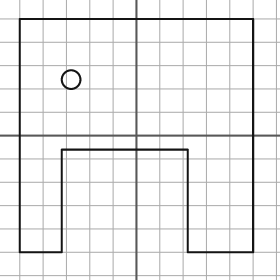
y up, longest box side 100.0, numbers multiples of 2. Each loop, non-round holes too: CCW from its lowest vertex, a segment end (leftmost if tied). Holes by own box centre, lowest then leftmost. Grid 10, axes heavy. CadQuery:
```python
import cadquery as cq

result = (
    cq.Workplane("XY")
    .moveTo(-50.0, -50.0)
    .lineTo(-32.0, -50.0)
    .lineTo(-32.0, -6.0)
    .lineTo(22.0, -6.0)
    .lineTo(22.0, -50.0)
    .lineTo(50.0, -50.0)
    .lineTo(50.0, 50.0)
    .lineTo(-50.0, 50.0)
    .close()
    .moveTo(-28.0, 24.0)
    .circle(4.0)
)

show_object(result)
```